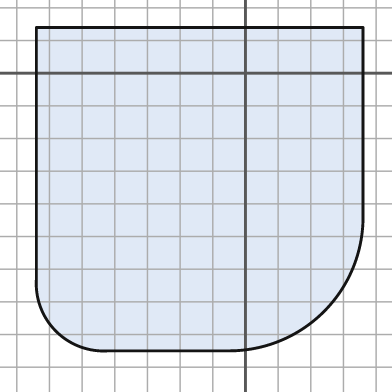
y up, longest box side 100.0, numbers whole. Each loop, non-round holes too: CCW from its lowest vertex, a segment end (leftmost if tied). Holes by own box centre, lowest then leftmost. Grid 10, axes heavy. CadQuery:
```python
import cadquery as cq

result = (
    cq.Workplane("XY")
    .moveTo(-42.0, -85.0)
    .lineTo(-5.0, -85.0)
    .threePointArc((24.0, -73.0), (36.0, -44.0))
    .lineTo(36.0, 14.0)
    .lineTo(-64.0, 14.0)
    .lineTo(-64.0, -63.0)
    .threePointArc((-58.0, -79.0), (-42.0, -85.0))
    .close()
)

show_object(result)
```